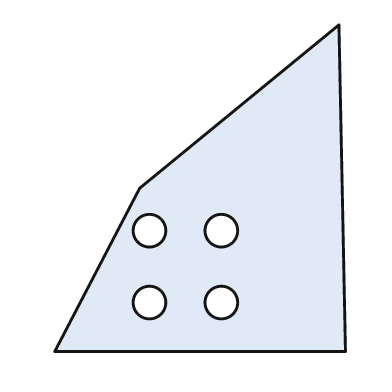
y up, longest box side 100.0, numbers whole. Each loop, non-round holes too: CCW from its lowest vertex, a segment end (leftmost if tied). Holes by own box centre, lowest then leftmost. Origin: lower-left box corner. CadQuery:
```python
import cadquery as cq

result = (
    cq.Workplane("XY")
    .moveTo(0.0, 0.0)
    .lineTo(89.0, 0.0)
    .lineTo(87.0, 100.0)
    .lineTo(26.0, 50.0)
    .close()
    .moveTo(29.0, 15.0)
    .circle(5.0)
    .moveTo(51.0, 15.0)
    .circle(5.0)
    .moveTo(29.0, 37.0)
    .circle(5.0)
    .moveTo(51.0, 37.0)
    .circle(5.0)
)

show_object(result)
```